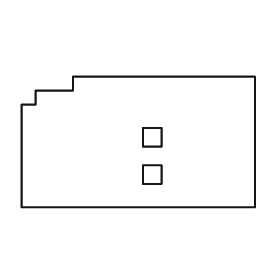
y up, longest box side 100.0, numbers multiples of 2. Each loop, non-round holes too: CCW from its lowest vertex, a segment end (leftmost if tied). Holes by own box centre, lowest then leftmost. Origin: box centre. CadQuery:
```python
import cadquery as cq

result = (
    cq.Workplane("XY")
    .moveTo(-50.0, -28.0)
    .lineTo(50.0, -28.0)
    .lineTo(50.0, 28.0)
    .lineTo(-28.0, 28.0)
    .lineTo(-28.0, 22.0)
    .lineTo(-44.0, 22.0)
    .lineTo(-44.0, 16.0)
    .lineTo(-50.0, 16.0)
    .close()
    .moveTo(2.0, -18.0)
    .lineTo(10.0, -18.0)
    .lineTo(10.0, -10.0)
    .lineTo(2.0, -10.0)
    .close()
    .moveTo(2.0, -2.0)
    .lineTo(10.0, -2.0)
    .lineTo(10.0, 6.0)
    .lineTo(2.0, 6.0)
    .close()
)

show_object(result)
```